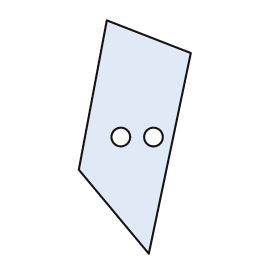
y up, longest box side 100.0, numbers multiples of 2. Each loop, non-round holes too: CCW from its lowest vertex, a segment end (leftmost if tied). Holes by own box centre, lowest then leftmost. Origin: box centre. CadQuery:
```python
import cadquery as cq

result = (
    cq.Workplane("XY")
    .moveTo(6.0, -50.0)
    .lineTo(24.0, 36.0)
    .lineTo(-12.0, 50.0)
    .lineTo(-24.0, -14.0)
    .close()
    .moveTo(-6.0, 0.0)
    .circle(4.0)
    .moveTo(8.0, 0.0)
    .circle(4.0)
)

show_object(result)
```